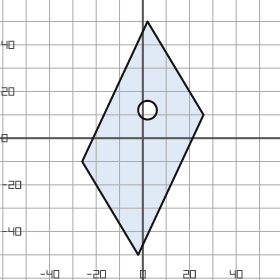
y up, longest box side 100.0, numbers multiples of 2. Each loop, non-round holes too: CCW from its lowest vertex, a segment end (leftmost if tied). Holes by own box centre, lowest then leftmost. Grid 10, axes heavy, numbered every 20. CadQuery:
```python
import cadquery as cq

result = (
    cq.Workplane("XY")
    .moveTo(-2.0, -50.0)
    .lineTo(26.0, 10.0)
    .lineTo(2.0, 50.0)
    .lineTo(-26.0, -10.0)
    .close()
    .moveTo(2.0, 12.0)
    .circle(4.0)
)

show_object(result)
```